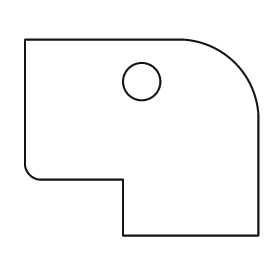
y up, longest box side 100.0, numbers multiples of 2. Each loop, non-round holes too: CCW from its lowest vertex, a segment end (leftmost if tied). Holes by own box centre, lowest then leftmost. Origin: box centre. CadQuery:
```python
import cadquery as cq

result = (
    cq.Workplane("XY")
    .moveTo(-8.0, -42.0)
    .lineTo(50.0, -42.0)
    .lineTo(50.0, 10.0)
    .threePointArc((40.0, 32.0), (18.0, 42.0))
    .lineTo(-50.0, 42.0)
    .lineTo(-50.0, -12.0)
    .threePointArc((-48.0, -16.0), (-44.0, -18.0))
    .lineTo(-8.0, -18.0)
    .close()
    .moveTo(0.0, 24.0)
    .circle(8.0)
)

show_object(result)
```